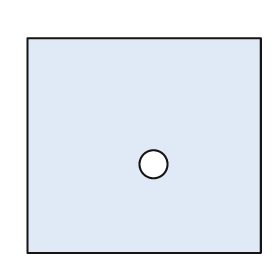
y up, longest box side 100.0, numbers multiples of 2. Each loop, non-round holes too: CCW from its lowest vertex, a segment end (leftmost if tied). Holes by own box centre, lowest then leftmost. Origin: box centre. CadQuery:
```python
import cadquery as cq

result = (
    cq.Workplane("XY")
    .moveTo(-50.0, -46.0)
    .lineTo(50.0, -46.0)
    .lineTo(50.0, 46.0)
    .lineTo(-50.0, 46.0)
    .close()
    .moveTo(4.0, -8.0)
    .circle(6.0)
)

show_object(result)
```